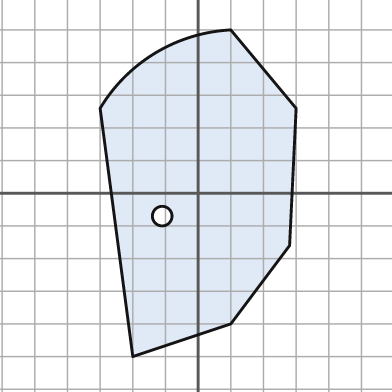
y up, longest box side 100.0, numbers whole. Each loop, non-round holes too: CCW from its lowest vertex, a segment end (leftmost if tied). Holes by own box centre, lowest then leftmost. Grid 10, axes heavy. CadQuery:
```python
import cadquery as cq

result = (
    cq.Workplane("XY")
    .moveTo(-20.0, -50.0)
    .lineTo(10.0, -40.0)
    .lineTo(28.0, -16.0)
    .lineTo(30.0, 26.0)
    .lineTo(10.0, 50.0)
    .threePointArc((-13.0, 43.0), (-30.0, 26.0))
    .close()
    .moveTo(-11.0, -7.0)
    .circle(3.0)
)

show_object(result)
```